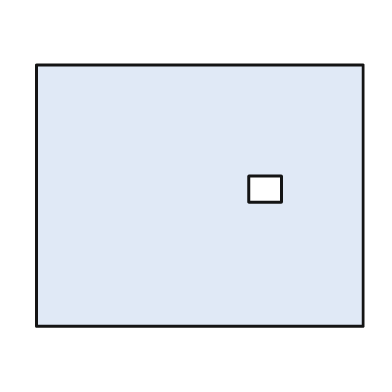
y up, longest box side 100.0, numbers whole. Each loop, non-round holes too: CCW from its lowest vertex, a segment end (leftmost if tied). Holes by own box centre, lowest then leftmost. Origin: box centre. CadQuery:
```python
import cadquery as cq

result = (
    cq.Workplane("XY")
    .moveTo(-50.0, -40.0)
    .lineTo(50.0, -40.0)
    .lineTo(50.0, 40.0)
    .lineTo(-50.0, 40.0)
    .close()
    .moveTo(15.0, -2.0)
    .lineTo(25.0, -2.0)
    .lineTo(25.0, 6.0)
    .lineTo(15.0, 6.0)
    .close()
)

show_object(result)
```